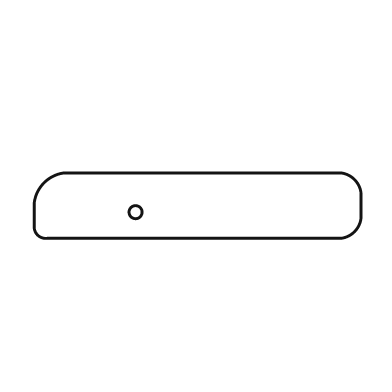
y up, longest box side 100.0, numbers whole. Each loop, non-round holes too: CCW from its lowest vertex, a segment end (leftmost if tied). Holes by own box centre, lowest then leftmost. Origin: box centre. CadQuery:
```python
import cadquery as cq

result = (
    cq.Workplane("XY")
    .moveTo(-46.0, -10.0)
    .lineTo(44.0, -10.0)
    .threePointArc((48.0, -8.0), (50.0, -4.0))
    .lineTo(50.0, 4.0)
    .threePointArc((48.0, 8.0), (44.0, 10.0))
    .lineTo(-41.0, 10.0)
    .threePointArc((-47.0, 7.0), (-50.0, 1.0))
    .lineTo(-50.0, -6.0)
    .threePointArc((-49.0, -9.0), (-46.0, -10.0))
    .close()
    .moveTo(-19.0, -2.0)
    .circle(2.0)
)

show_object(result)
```